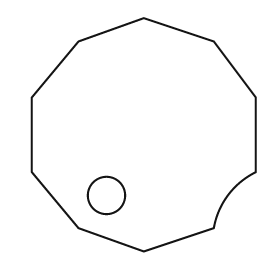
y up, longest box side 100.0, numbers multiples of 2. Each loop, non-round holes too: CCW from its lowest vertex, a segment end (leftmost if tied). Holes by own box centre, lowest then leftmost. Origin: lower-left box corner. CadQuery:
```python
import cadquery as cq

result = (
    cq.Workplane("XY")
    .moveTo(48.0, 0.0)
    .lineTo(78.0, 10.0)
    .threePointArc((84.0, 24.0), (96.0, 34.0))
    .lineTo(96.0, 66.0)
    .lineTo(78.0, 90.0)
    .lineTo(48.0, 100.0)
    .lineTo(20.0, 90.0)
    .lineTo(0.0, 66.0)
    .lineTo(0.0, 34.0)
    .lineTo(20.0, 10.0)
    .close()
    .moveTo(32.0, 24.0)
    .circle(8.0)
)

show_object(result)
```